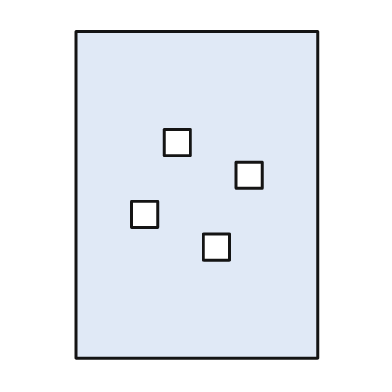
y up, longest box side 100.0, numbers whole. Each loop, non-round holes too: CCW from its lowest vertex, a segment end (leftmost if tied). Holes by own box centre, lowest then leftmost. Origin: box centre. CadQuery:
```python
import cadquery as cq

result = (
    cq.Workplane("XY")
    .moveTo(-37.0, -50.0)
    .lineTo(37.0, -50.0)
    .lineTo(37.0, 50.0)
    .lineTo(-37.0, 50.0)
    .close()
    .moveTo(2.0, -20.0)
    .lineTo(10.0, -20.0)
    .lineTo(10.0, -12.0)
    .lineTo(2.0, -12.0)
    .close()
    .moveTo(-20.0, -10.0)
    .lineTo(-12.0, -10.0)
    .lineTo(-12.0, -2.0)
    .lineTo(-20.0, -2.0)
    .close()
    .moveTo(12.0, 2.0)
    .lineTo(20.0, 2.0)
    .lineTo(20.0, 10.0)
    .lineTo(12.0, 10.0)
    .close()
    .moveTo(-10.0, 12.0)
    .lineTo(-2.0, 12.0)
    .lineTo(-2.0, 20.0)
    .lineTo(-10.0, 20.0)
    .close()
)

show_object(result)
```